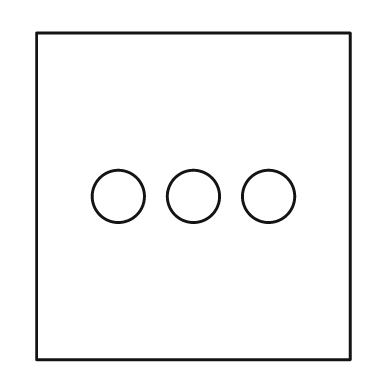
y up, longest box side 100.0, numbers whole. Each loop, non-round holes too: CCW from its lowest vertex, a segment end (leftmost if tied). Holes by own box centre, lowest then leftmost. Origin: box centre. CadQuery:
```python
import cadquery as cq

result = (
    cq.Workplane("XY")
    .moveTo(-48.0, -50.0)
    .lineTo(48.0, -50.0)
    .lineTo(48.0, 50.0)
    .lineTo(-48.0, 50.0)
    .close()
    .moveTo(-23.0, 0.0)
    .circle(8.0)
    .moveTo(0.0, 0.0)
    .circle(8.0)
    .moveTo(23.0, 0.0)
    .circle(8.0)
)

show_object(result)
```